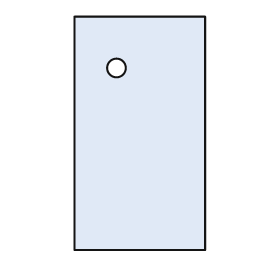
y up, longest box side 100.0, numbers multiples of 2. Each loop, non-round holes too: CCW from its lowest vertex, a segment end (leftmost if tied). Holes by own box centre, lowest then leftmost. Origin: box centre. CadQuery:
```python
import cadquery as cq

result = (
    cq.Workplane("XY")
    .moveTo(-28.0, -50.0)
    .lineTo(28.0, -50.0)
    .lineTo(28.0, 50.0)
    .lineTo(-28.0, 50.0)
    .close()
    .moveTo(-10.0, 28.0)
    .circle(4.0)
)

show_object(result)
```